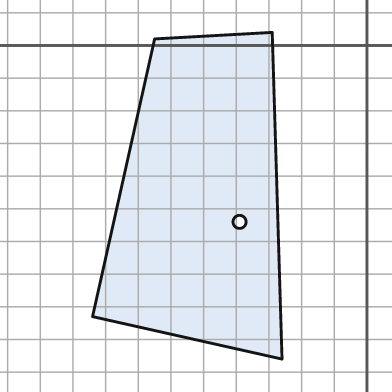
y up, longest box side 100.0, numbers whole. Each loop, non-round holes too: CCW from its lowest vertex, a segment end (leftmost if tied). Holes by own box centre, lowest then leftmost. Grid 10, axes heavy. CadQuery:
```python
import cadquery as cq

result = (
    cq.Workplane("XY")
    .moveTo(-26.0, -96.0)
    .lineTo(-29.0, 4.0)
    .lineTo(-65.0, 2.0)
    .lineTo(-84.0, -83.0)
    .close()
    .moveTo(-39.0, -54.0)
    .circle(2.0)
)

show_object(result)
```